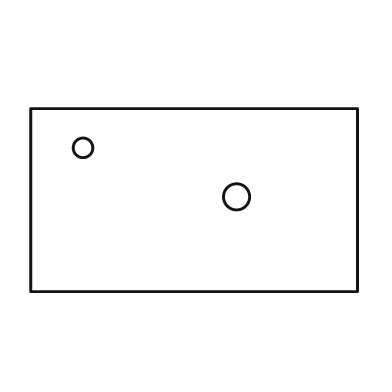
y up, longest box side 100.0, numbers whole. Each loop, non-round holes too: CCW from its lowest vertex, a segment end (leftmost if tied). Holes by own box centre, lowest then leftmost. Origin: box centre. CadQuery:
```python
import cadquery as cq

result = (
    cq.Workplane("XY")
    .moveTo(-50.0, -28.0)
    .lineTo(50.0, -28.0)
    .lineTo(50.0, 28.0)
    .lineTo(-50.0, 28.0)
    .close()
    .moveTo(13.0, 1.0)
    .circle(4.0)
    .moveTo(-34.0, 16.0)
    .circle(3.0)
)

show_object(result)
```